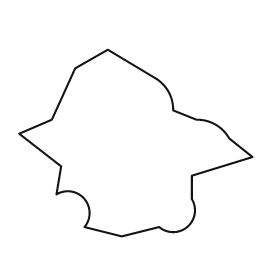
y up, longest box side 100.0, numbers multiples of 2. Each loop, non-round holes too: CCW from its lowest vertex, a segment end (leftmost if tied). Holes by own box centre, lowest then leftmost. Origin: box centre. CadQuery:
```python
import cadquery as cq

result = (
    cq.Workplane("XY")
    .moveTo(-6.0, -40.0)
    .lineTo(10.0, -36.0)
    .threePointArc((22.0, -36.0), (24.0, -24.0))
    .lineTo(24.0, -14.0)
    .lineTo(50.0, -6.0)
    .lineTo(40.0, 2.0)
    .threePointArc((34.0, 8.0), (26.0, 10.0))
    .lineTo(16.0, 14.0)
    .threePointArc((14.0, 22.0), (8.0, 28.0))
    .lineTo(-12.0, 40.0)
    .lineTo(-26.0, 32.0)
    .lineTo(-36.0, 10.0)
    .lineTo(-50.0, 4.0)
    .lineTo(-32.0, -10.0)
    .lineTo(-34.0, -22.0)
    .threePointArc((-22.0, -24.0), (-22.0, -36.0))
    .close()
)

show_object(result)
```